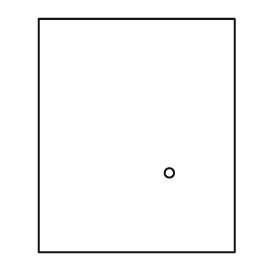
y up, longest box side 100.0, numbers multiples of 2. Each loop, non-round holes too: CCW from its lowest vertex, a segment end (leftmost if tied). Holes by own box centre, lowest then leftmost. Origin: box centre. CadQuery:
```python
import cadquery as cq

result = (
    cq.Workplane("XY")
    .moveTo(-42.0, -50.0)
    .lineTo(42.0, -50.0)
    .lineTo(42.0, 50.0)
    .lineTo(-42.0, 50.0)
    .close()
    .moveTo(14.0, -16.0)
    .circle(2.0)
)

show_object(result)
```